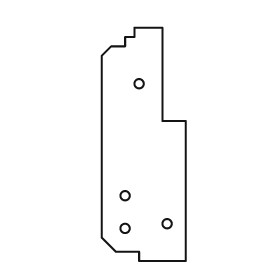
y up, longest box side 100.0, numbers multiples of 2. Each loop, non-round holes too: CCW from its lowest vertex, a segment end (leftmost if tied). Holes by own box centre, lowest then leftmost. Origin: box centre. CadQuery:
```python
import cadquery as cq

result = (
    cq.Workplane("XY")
    .moveTo(-2.0, -50.0)
    .lineTo(18.0, -50.0)
    .lineTo(18.0, 10.0)
    .lineTo(8.0, 10.0)
    .lineTo(8.0, 50.0)
    .lineTo(-4.0, 50.0)
    .lineTo(-4.0, 46.0)
    .lineTo(-8.0, 46.0)
    .lineTo(-8.0, 42.0)
    .lineTo(-14.0, 42.0)
    .lineTo(-18.0, 38.0)
    .lineTo(-18.0, -40.0)
    .lineTo(-12.0, -46.0)
    .lineTo(-2.0, -46.0)
    .close()
    .moveTo(-8.0, -36.0)
    .circle(2.0)
    .moveTo(10.0, -34.0)
    .circle(2.0)
    .moveTo(-8.0, -22.0)
    .circle(2.0)
    .moveTo(-2.0, 26.0)
    .circle(2.0)
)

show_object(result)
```